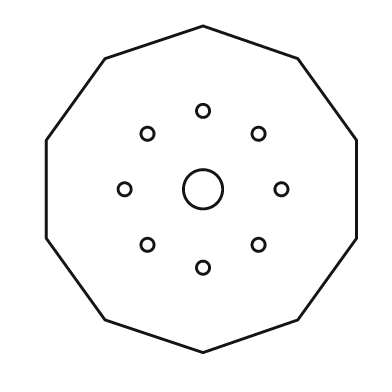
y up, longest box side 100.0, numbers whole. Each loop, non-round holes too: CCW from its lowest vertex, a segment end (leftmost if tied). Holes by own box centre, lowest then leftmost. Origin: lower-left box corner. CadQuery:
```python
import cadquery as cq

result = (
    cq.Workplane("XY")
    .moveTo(48.0, 0.0)
    .lineTo(77.0, 10.0)
    .lineTo(95.0, 35.0)
    .lineTo(95.0, 65.0)
    .lineTo(77.0, 90.0)
    .lineTo(48.0, 100.0)
    .lineTo(18.0, 90.0)
    .lineTo(0.0, 65.0)
    .lineTo(0.0, 35.0)
    .lineTo(18.0, 10.0)
    .close()
    .moveTo(48.0, 26.0)
    .circle(2.0)
    .moveTo(31.0, 33.0)
    .circle(2.0)
    .moveTo(65.0, 33.0)
    .circle(2.0)
    .moveTo(24.0, 50.0)
    .circle(2.0)
    .moveTo(48.0, 50.0)
    .circle(6.0)
    .moveTo(72.0, 50.0)
    .circle(2.0)
    .moveTo(31.0, 67.0)
    .circle(2.0)
    .moveTo(65.0, 67.0)
    .circle(2.0)
    .moveTo(48.0, 74.0)
    .circle(2.0)
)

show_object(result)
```